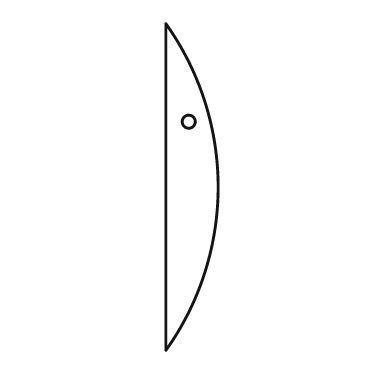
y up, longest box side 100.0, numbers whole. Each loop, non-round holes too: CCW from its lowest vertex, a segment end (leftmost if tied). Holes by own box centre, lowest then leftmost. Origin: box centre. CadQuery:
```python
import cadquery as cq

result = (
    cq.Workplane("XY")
    .moveTo(-8.0, -50.0)
    .threePointArc((8.0, 0.0), (-8.0, 50.0))
    .close()
    .moveTo(-1.0, 20.0)
    .circle(2.0)
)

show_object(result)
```